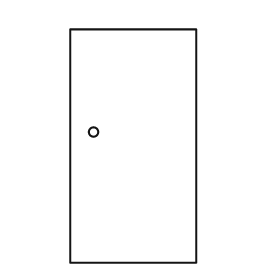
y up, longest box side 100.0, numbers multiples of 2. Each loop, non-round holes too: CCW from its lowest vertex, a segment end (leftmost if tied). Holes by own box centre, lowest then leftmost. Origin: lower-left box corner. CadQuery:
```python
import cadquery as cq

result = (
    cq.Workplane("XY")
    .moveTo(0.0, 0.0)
    .lineTo(54.0, 0.0)
    .lineTo(54.0, 100.0)
    .lineTo(0.0, 100.0)
    .close()
    .moveTo(10.0, 56.0)
    .circle(2.0)
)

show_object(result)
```